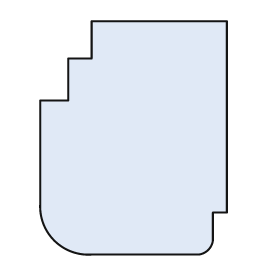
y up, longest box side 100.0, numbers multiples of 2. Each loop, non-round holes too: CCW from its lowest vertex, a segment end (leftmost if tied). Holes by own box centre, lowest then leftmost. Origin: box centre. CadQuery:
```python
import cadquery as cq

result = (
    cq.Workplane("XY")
    .moveTo(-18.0, -50.0)
    .lineTo(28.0, -50.0)
    .threePointArc((32.0, -48.0), (34.0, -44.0))
    .lineTo(34.0, -32.0)
    .lineTo(40.0, -32.0)
    .lineTo(40.0, 50.0)
    .lineTo(-18.0, 50.0)
    .lineTo(-18.0, 34.0)
    .lineTo(-28.0, 34.0)
    .lineTo(-28.0, 16.0)
    .lineTo(-40.0, 16.0)
    .lineTo(-40.0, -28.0)
    .threePointArc((-34.0, -44.0), (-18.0, -50.0))
    .close()
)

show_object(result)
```